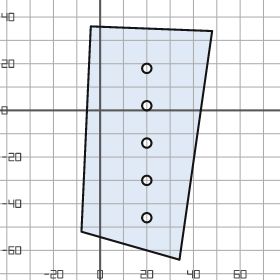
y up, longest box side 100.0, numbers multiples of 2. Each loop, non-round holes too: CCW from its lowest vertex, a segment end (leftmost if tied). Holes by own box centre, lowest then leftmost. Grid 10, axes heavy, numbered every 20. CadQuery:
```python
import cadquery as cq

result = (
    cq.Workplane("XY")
    .moveTo(34.0, -64.0)
    .lineTo(48.0, 34.0)
    .lineTo(-4.0, 36.0)
    .lineTo(-8.0, -52.0)
    .close()
    .moveTo(20.0, -46.0)
    .circle(2.0)
    .moveTo(20.0, -30.0)
    .circle(2.0)
    .moveTo(20.0, -14.0)
    .circle(2.0)
    .moveTo(20.0, 2.0)
    .circle(2.0)
    .moveTo(20.0, 18.0)
    .circle(2.0)
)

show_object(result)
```